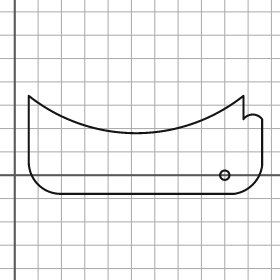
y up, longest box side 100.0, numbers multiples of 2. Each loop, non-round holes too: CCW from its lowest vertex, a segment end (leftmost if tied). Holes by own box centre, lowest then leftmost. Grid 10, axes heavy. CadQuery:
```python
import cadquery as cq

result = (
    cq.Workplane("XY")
    .moveTo(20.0, -8.0)
    .lineTo(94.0, -8.0)
    .threePointArc((102.0, -4.0), (106.0, 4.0))
    .lineTo(106.0, 24.0)
    .threePointArc((102.0, 26.0), (98.0, 24.0))
    .lineTo(98.0, 34.0)
    .threePointArc((52.0, 18.0), (6.0, 34.0))
    .lineTo(6.0, 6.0)
    .threePointArc((10.0, -4.0), (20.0, -8.0))
    .close()
    .moveTo(90.0, 0.0)
    .circle(2.0)
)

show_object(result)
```